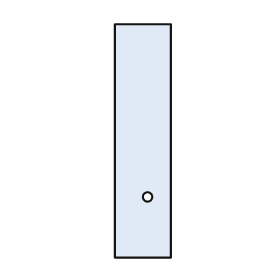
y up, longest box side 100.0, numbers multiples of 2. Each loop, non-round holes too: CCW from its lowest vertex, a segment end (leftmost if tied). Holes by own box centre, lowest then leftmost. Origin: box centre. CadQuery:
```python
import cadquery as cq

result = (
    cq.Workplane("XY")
    .moveTo(-12.0, -50.0)
    .lineTo(12.0, -50.0)
    .lineTo(12.0, 50.0)
    .lineTo(-12.0, 50.0)
    .close()
    .moveTo(2.0, -24.0)
    .circle(2.0)
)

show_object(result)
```